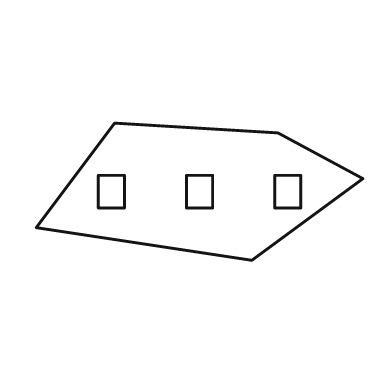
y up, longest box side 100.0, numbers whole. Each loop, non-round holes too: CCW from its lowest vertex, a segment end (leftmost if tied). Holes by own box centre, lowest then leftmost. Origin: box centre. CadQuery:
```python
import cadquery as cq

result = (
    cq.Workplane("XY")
    .moveTo(16.0, -21.0)
    .lineTo(50.0, 4.0)
    .lineTo(24.0, 18.0)
    .lineTo(-26.0, 21.0)
    .lineTo(-50.0, -11.0)
    .close()
    .moveTo(-31.0, -5.0)
    .lineTo(-23.0, -5.0)
    .lineTo(-23.0, 5.0)
    .lineTo(-31.0, 5.0)
    .close()
    .moveTo(-4.0, -5.0)
    .lineTo(4.0, -5.0)
    .lineTo(4.0, 5.0)
    .lineTo(-4.0, 5.0)
    .close()
    .moveTo(23.0, -5.0)
    .lineTo(31.0, -5.0)
    .lineTo(31.0, 5.0)
    .lineTo(23.0, 5.0)
    .close()
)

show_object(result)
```